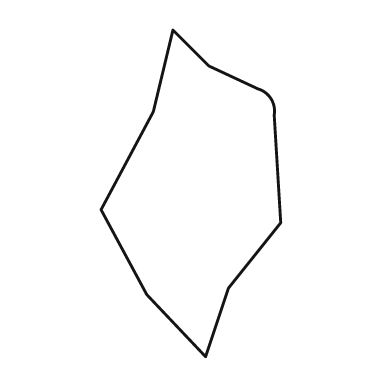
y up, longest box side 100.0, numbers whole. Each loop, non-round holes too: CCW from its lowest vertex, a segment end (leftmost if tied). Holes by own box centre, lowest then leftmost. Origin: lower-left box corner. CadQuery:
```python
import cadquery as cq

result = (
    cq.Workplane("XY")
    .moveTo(32.0, 0.0)
    .lineTo(39.0, 21.0)
    .lineTo(55.0, 41.0)
    .lineTo(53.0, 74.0)
    .threePointArc((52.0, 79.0), (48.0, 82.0))
    .lineTo(33.0, 89.0)
    .lineTo(22.0, 100.0)
    .lineTo(16.0, 75.0)
    .lineTo(0.0, 45.0)
    .lineTo(14.0, 19.0)
    .close()
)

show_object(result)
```